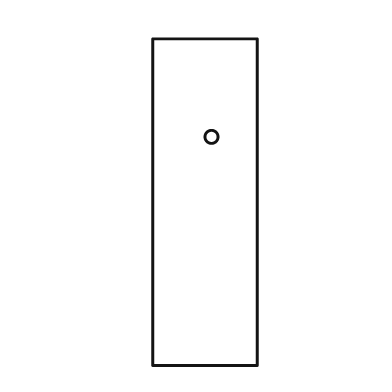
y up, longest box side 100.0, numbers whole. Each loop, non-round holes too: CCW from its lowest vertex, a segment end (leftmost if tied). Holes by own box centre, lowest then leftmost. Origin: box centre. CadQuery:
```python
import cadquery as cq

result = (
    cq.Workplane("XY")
    .moveTo(-16.0, -50.0)
    .lineTo(16.0, -50.0)
    .lineTo(16.0, 50.0)
    .lineTo(-16.0, 50.0)
    .close()
    .moveTo(2.0, 20.0)
    .circle(2.0)
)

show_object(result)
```